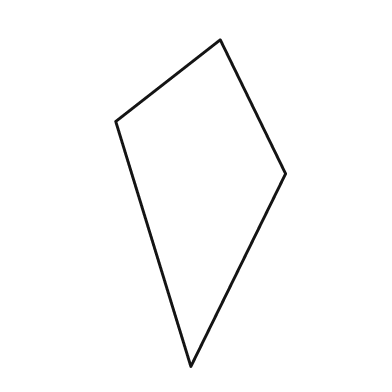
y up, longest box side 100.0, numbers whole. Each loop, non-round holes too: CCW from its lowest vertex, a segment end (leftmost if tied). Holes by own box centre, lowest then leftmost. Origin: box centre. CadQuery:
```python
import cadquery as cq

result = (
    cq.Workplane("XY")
    .moveTo(-3.0, -50.0)
    .lineTo(26.0, 9.0)
    .lineTo(6.0, 50.0)
    .lineTo(-26.0, 25.0)
    .close()
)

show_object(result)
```